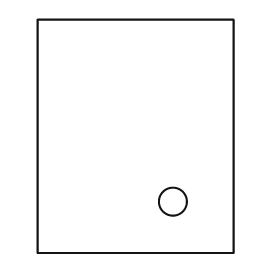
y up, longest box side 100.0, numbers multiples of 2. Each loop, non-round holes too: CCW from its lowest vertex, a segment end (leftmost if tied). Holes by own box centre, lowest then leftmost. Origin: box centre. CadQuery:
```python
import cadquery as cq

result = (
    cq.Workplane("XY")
    .moveTo(-42.0, -50.0)
    .lineTo(42.0, -50.0)
    .lineTo(42.0, 50.0)
    .lineTo(-42.0, 50.0)
    .close()
    .moveTo(16.0, -28.0)
    .circle(6.0)
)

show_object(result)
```